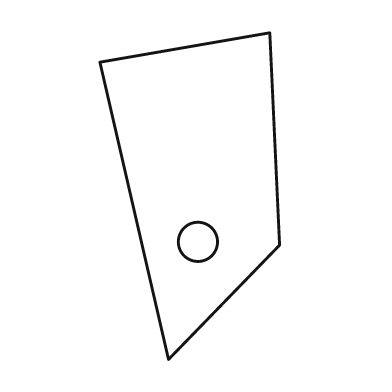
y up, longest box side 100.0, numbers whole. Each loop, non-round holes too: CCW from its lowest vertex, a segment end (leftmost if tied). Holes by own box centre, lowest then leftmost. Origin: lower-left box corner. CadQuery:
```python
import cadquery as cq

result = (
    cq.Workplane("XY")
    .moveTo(21.0, 0.0)
    .lineTo(55.0, 35.0)
    .lineTo(52.0, 100.0)
    .lineTo(0.0, 91.0)
    .close()
    .moveTo(30.0, 36.0)
    .circle(6.0)
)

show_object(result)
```